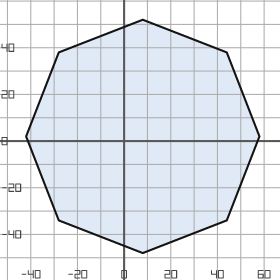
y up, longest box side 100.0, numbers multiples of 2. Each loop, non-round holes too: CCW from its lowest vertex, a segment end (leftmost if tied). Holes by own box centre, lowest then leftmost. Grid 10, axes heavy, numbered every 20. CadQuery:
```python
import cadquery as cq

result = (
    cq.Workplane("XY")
    .moveTo(8.0, -48.0)
    .lineTo(44.0, -34.0)
    .lineTo(58.0, 2.0)
    .lineTo(44.0, 38.0)
    .lineTo(8.0, 52.0)
    .lineTo(-28.0, 38.0)
    .lineTo(-42.0, 2.0)
    .lineTo(-28.0, -34.0)
    .close()
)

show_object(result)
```